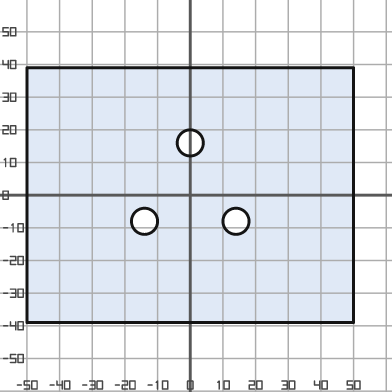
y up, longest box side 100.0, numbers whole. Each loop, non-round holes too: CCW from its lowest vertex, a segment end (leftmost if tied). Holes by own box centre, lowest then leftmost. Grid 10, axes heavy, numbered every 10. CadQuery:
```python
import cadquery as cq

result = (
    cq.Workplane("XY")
    .moveTo(-50.0, -39.0)
    .lineTo(50.0, -39.0)
    .lineTo(50.0, 39.0)
    .lineTo(-50.0, 39.0)
    .close()
    .moveTo(-14.0, -8.0)
    .circle(4.0)
    .moveTo(14.0, -8.0)
    .circle(4.0)
    .moveTo(0.0, 16.0)
    .circle(4.0)
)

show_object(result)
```